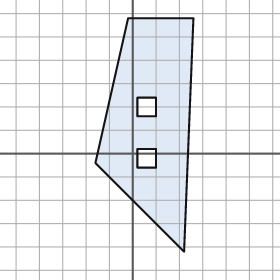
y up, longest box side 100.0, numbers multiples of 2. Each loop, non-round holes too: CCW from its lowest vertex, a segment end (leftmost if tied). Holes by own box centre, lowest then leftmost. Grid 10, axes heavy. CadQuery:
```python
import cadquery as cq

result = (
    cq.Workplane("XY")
    .moveTo(22.0, -42.0)
    .lineTo(26.0, 58.0)
    .lineTo(-2.0, 58.0)
    .lineTo(-16.0, -4.0)
    .close()
    .moveTo(2.0, -6.0)
    .lineTo(10.0, -6.0)
    .lineTo(10.0, 2.0)
    .lineTo(2.0, 2.0)
    .close()
    .moveTo(2.0, 16.0)
    .lineTo(10.0, 16.0)
    .lineTo(10.0, 24.0)
    .lineTo(2.0, 24.0)
    .close()
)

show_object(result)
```